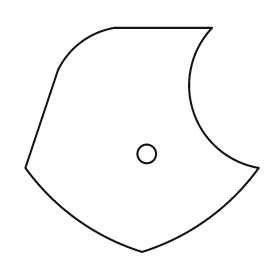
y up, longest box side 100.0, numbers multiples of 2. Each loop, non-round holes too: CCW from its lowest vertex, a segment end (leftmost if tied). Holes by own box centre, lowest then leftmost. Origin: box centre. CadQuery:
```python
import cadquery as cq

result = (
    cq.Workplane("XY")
    .moveTo(0.0, -48.0)
    .threePointArc((28.0, -34.0), (50.0, -12.0))
    .threePointArc((22.0, 12.0), (30.0, 48.0))
    .lineTo(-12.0, 48.0)
    .threePointArc((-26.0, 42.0), (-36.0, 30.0))
    .lineTo(-50.0, -12.0)
    .threePointArc((-28.0, -34.0), (0.0, -48.0))
    .close()
    .moveTo(2.0, -6.0)
    .circle(4.0)
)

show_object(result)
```